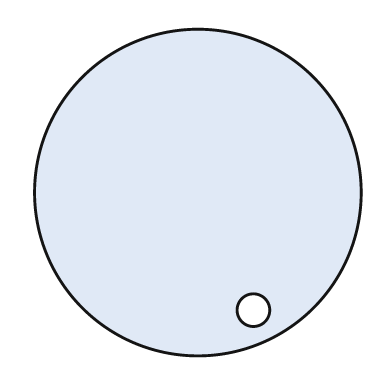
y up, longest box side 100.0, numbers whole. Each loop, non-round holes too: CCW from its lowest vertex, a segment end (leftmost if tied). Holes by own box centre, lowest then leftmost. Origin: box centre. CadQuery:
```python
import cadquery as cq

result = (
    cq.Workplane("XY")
    .moveTo(0.0, 0.0)
    .circle(50.0)
    .moveTo(17.0, -36.0)
    .circle(5.0)
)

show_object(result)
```